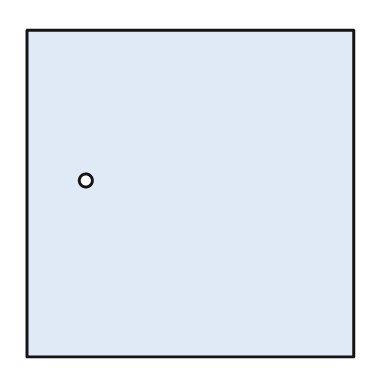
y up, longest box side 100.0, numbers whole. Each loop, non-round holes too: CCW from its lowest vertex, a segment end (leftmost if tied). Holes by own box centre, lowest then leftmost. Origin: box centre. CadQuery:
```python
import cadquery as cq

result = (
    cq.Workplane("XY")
    .moveTo(-50.0, -50.0)
    .lineTo(50.0, -50.0)
    .lineTo(50.0, 50.0)
    .lineTo(-50.0, 50.0)
    .close()
    .moveTo(-32.0, 4.0)
    .circle(2.0)
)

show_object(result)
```